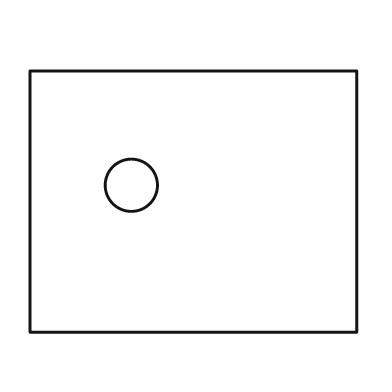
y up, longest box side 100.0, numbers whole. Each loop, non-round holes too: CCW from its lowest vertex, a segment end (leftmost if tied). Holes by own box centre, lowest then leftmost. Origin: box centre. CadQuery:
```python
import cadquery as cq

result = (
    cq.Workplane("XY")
    .moveTo(-50.0, -40.0)
    .lineTo(50.0, -40.0)
    .lineTo(50.0, 40.0)
    .lineTo(-50.0, 40.0)
    .close()
    .moveTo(-19.0, 5.0)
    .circle(8.0)
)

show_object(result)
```